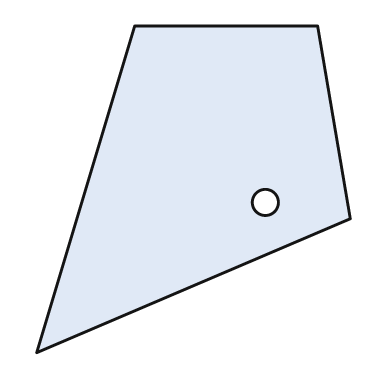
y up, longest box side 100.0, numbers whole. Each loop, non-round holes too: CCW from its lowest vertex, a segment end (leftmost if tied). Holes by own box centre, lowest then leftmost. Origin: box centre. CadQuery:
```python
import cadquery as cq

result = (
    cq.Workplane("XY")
    .moveTo(-48.0, -50.0)
    .lineTo(48.0, -9.0)
    .lineTo(38.0, 50.0)
    .lineTo(-18.0, 50.0)
    .close()
    .moveTo(22.0, -4.0)
    .circle(4.0)
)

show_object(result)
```